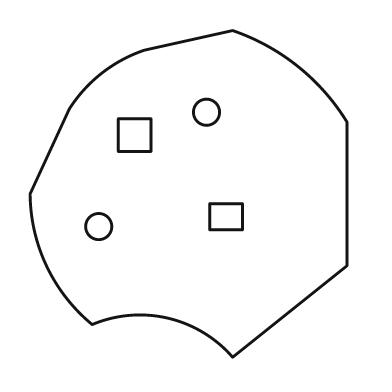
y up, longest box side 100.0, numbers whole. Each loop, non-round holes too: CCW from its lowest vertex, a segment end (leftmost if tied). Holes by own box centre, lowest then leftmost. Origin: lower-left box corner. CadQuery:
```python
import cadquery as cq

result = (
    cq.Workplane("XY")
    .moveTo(62.0, 0.0)
    .lineTo(97.0, 28.0)
    .lineTo(97.0, 72.0)
    .threePointArc((82.0, 89.0), (62.0, 100.0))
    .lineTo(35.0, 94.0)
    .threePointArc((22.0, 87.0), (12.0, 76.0))
    .lineTo(0.0, 50.0)
    .threePointArc((5.0, 28.0), (19.0, 10.0))
    .threePointArc((42.0, 12.0), (62.0, 0.0))
    .close()
    .moveTo(21.0, 40.0)
    .circle(4.0)
    .moveTo(55.0, 39.0)
    .lineTo(65.0, 39.0)
    .lineTo(65.0, 47.0)
    .lineTo(55.0, 47.0)
    .close()
    .moveTo(27.0, 63.0)
    .lineTo(37.0, 63.0)
    .lineTo(37.0, 73.0)
    .lineTo(27.0, 73.0)
    .close()
    .moveTo(54.0, 75.0)
    .circle(4.0)
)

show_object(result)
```